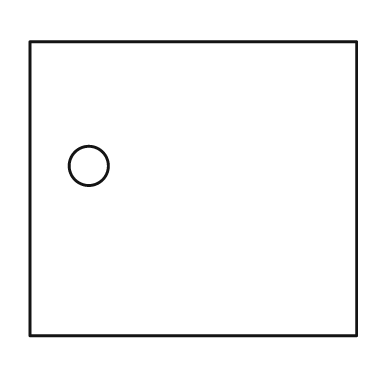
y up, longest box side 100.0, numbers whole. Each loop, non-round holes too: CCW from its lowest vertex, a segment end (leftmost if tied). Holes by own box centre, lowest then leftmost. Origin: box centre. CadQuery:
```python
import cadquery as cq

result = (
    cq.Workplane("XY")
    .moveTo(-50.0, -45.0)
    .lineTo(50.0, -45.0)
    .lineTo(50.0, 45.0)
    .lineTo(-50.0, 45.0)
    .close()
    .moveTo(-32.0, 7.0)
    .circle(6.0)
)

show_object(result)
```